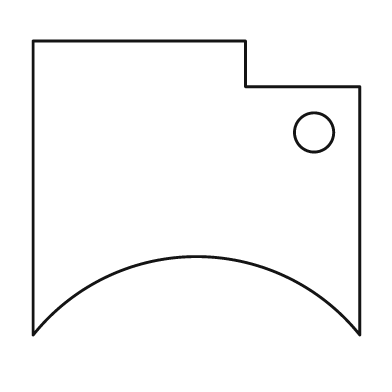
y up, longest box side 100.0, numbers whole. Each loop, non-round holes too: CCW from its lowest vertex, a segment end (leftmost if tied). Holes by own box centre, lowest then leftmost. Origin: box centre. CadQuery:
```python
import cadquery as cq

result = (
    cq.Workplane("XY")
    .moveTo(-50.0, -45.0)
    .threePointArc((0.0, -21.0), (50.0, -45.0))
    .lineTo(50.0, 31.0)
    .lineTo(15.0, 31.0)
    .lineTo(15.0, 45.0)
    .lineTo(-50.0, 45.0)
    .close()
    .moveTo(36.0, 17.0)
    .circle(6.0)
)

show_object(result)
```